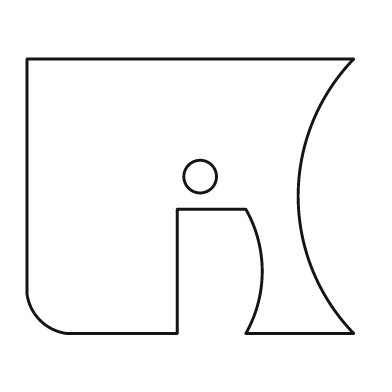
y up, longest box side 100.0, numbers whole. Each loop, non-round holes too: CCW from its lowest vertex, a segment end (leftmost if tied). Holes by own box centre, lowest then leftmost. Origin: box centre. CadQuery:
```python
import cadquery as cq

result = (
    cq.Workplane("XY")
    .moveTo(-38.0, -42.0)
    .lineTo(-4.0, -42.0)
    .lineTo(-4.0, -4.0)
    .lineTo(17.0, -4.0)
    .threePointArc((22.0, -23.0), (17.0, -42.0))
    .lineTo(50.0, -42.0)
    .threePointArc((33.0, 0.0), (50.0, 42.0))
    .lineTo(-50.0, 42.0)
    .lineTo(-50.0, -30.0)
    .threePointArc((-46.0, -38.0), (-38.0, -42.0))
    .close()
    .moveTo(3.0, 6.0)
    .circle(5.0)
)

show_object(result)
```